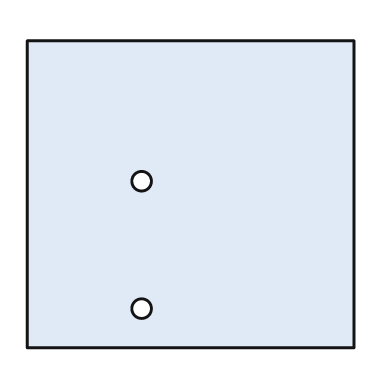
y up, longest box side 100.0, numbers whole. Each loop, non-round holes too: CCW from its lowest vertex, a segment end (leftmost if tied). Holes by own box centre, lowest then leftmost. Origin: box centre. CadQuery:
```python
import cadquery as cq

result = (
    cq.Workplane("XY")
    .moveTo(-50.0, -47.0)
    .lineTo(50.0, -47.0)
    .lineTo(50.0, 47.0)
    .lineTo(-50.0, 47.0)
    .close()
    .moveTo(-15.0, -35.0)
    .circle(3.0)
    .moveTo(-15.0, 4.0)
    .circle(3.0)
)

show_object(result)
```